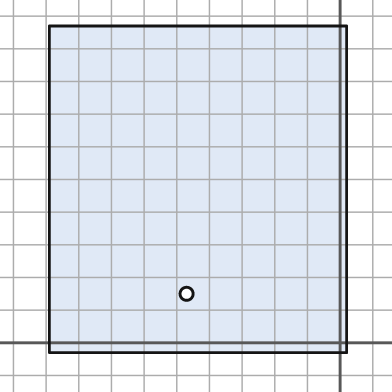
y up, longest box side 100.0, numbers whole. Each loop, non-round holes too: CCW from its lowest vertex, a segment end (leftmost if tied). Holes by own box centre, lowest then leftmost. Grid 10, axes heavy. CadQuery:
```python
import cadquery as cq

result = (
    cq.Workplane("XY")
    .moveTo(-89.0, -3.0)
    .lineTo(2.0, -3.0)
    .lineTo(2.0, 97.0)
    .lineTo(-89.0, 97.0)
    .close()
    .moveTo(-47.0, 15.0)
    .circle(2.0)
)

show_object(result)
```